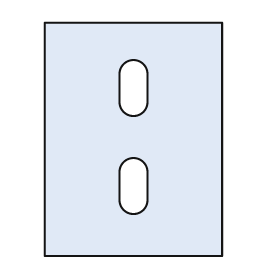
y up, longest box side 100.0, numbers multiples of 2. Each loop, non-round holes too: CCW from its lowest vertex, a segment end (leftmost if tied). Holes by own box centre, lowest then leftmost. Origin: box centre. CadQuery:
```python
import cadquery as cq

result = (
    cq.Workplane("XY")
    .moveTo(-38.0, -50.0)
    .lineTo(38.0, -50.0)
    .lineTo(38.0, 50.0)
    .lineTo(-38.0, 50.0)
    .close()
    .moveTo(-6.0, -26.0)
    .threePointArc((0.0, -32.0), (6.0, -26.0))
    .lineTo(6.0, -14.0)
    .threePointArc((0.0, -8.0), (-6.0, -14.0))
    .close()
    .moveTo(-6.0, 16.0)
    .threePointArc((0.0, 10.0), (6.0, 16.0))
    .lineTo(6.0, 28.0)
    .threePointArc((0.0, 34.0), (-6.0, 28.0))
    .close()
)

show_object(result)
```